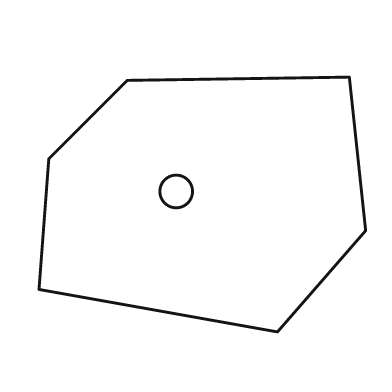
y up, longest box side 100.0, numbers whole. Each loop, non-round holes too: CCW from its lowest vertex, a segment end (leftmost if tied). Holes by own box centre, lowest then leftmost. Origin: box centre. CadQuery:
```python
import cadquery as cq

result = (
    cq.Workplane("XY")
    .moveTo(23.0, -39.0)
    .lineTo(50.0, -8.0)
    .lineTo(45.0, 39.0)
    .lineTo(-23.0, 38.0)
    .lineTo(-47.0, 14.0)
    .lineTo(-50.0, -26.0)
    .close()
    .moveTo(-8.0, 4.0)
    .circle(5.0)
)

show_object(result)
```